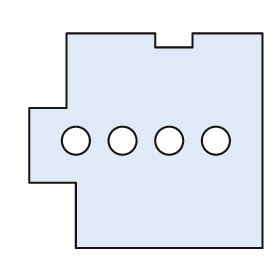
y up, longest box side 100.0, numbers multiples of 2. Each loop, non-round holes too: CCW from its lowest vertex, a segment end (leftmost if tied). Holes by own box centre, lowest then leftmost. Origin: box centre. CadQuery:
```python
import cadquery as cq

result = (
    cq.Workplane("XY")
    .moveTo(-30.0, -46.0)
    .lineTo(50.0, -46.0)
    .lineTo(50.0, 46.0)
    .lineTo(20.0, 46.0)
    .lineTo(20.0, 40.0)
    .lineTo(4.0, 40.0)
    .lineTo(4.0, 46.0)
    .lineTo(-34.0, 46.0)
    .lineTo(-34.0, 14.0)
    .lineTo(-50.0, 14.0)
    .lineTo(-50.0, -18.0)
    .lineTo(-30.0, -18.0)
    .close()
    .moveTo(-30.0, 0.0)
    .circle(6.0)
    .moveTo(-10.0, 0.0)
    .circle(6.0)
    .moveTo(10.0, 0.0)
    .circle(6.0)
    .moveTo(30.0, 0.0)
    .circle(6.0)
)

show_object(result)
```